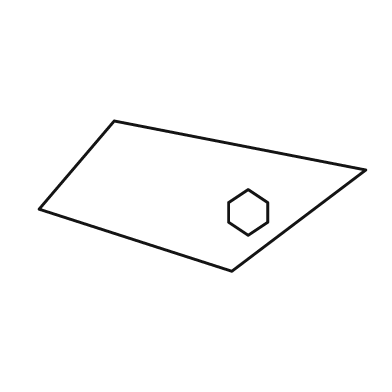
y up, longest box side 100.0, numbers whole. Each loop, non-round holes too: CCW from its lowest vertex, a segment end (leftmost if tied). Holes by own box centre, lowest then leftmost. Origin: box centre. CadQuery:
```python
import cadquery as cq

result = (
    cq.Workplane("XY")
    .moveTo(9.0, -23.0)
    .lineTo(50.0, 8.0)
    .lineTo(-27.0, 23.0)
    .lineTo(-50.0, -4.0)
    .close()
    .moveTo(14.0, -12.0)
    .lineTo(20.0, -8.0)
    .lineTo(20.0, -2.0)
    .lineTo(14.0, 2.0)
    .lineTo(8.0, -2.0)
    .lineTo(8.0, -8.0)
    .close()
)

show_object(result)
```